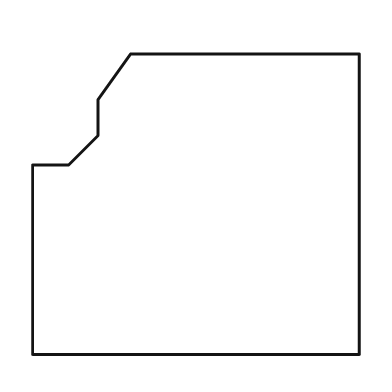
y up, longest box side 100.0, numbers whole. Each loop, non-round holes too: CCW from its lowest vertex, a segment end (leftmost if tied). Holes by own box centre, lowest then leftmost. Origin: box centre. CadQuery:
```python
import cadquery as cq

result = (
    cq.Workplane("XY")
    .moveTo(-50.0, -46.0)
    .lineTo(50.0, -46.0)
    .lineTo(50.0, 46.0)
    .lineTo(-20.0, 46.0)
    .lineTo(-30.0, 32.0)
    .lineTo(-30.0, 21.0)
    .lineTo(-39.0, 12.0)
    .lineTo(-50.0, 12.0)
    .close()
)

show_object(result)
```